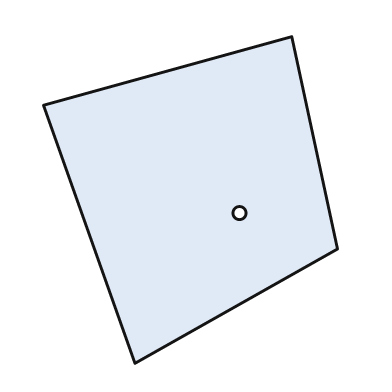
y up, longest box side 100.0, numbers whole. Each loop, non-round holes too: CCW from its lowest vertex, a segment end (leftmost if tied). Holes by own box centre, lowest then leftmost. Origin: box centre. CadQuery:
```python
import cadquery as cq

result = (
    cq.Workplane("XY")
    .moveTo(-17.0, -50.0)
    .lineTo(45.0, -15.0)
    .lineTo(31.0, 50.0)
    .lineTo(-45.0, 29.0)
    .close()
    .moveTo(15.0, -4.0)
    .circle(2.0)
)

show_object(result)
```